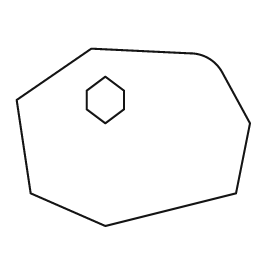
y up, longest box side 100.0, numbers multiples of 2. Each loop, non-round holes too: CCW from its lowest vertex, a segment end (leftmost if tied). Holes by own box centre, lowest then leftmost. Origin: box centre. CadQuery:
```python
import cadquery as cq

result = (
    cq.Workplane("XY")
    .moveTo(-12.0, -38.0)
    .lineTo(44.0, -24.0)
    .lineTo(50.0, 6.0)
    .lineTo(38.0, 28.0)
    .threePointArc((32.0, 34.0), (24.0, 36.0))
    .lineTo(-18.0, 38.0)
    .lineTo(-50.0, 16.0)
    .lineTo(-44.0, -24.0)
    .close()
    .moveTo(-12.0, 6.0)
    .lineTo(-4.0, 12.0)
    .lineTo(-4.0, 20.0)
    .lineTo(-12.0, 26.0)
    .lineTo(-20.0, 20.0)
    .lineTo(-20.0, 12.0)
    .close()
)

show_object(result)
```